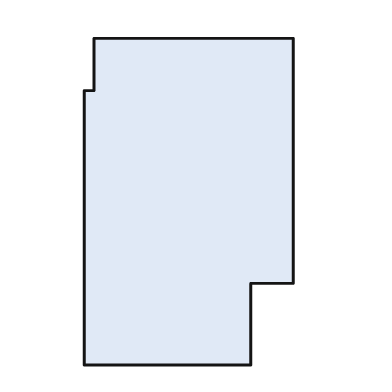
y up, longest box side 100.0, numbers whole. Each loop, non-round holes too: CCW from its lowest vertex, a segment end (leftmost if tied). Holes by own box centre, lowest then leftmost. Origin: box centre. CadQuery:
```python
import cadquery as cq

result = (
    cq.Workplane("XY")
    .moveTo(-32.0, -50.0)
    .lineTo(19.0, -50.0)
    .lineTo(19.0, -25.0)
    .lineTo(32.0, -25.0)
    .lineTo(32.0, 50.0)
    .lineTo(-29.0, 50.0)
    .lineTo(-29.0, 34.0)
    .lineTo(-32.0, 34.0)
    .close()
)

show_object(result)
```